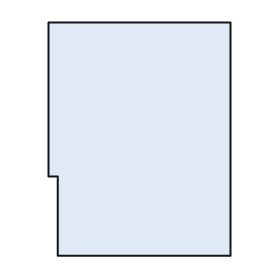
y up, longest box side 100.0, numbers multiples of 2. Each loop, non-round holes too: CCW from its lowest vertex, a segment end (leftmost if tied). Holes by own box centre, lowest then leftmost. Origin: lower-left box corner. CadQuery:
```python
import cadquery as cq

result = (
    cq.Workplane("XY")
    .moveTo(4.0, 0.0)
    .lineTo(78.0, 0.0)
    .lineTo(78.0, 100.0)
    .lineTo(0.0, 100.0)
    .lineTo(0.0, 34.0)
    .lineTo(4.0, 34.0)
    .close()
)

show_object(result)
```